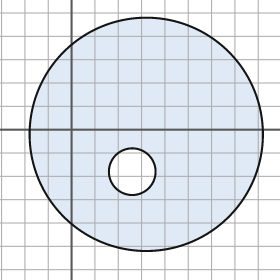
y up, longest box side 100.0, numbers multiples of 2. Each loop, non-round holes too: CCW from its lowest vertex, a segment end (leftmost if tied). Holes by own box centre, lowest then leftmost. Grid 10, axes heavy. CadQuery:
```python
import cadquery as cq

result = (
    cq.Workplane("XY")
    .moveTo(32.0, -2.0)
    .circle(50.0)
    .moveTo(26.0, -18.0)
    .circle(10.0)
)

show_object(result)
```